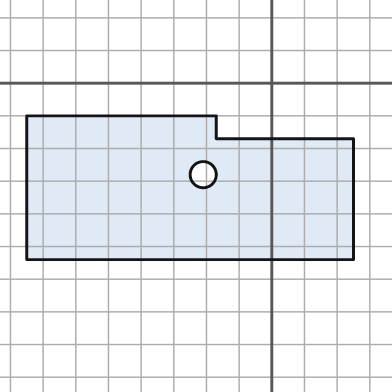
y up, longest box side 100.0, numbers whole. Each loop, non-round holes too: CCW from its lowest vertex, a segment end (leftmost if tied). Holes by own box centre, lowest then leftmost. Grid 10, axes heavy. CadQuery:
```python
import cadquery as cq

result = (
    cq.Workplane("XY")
    .moveTo(-75.0, -54.0)
    .lineTo(25.0, -54.0)
    .lineTo(25.0, -17.0)
    .lineTo(-17.0, -17.0)
    .lineTo(-17.0, -10.0)
    .lineTo(-75.0, -10.0)
    .close()
    .moveTo(-21.0, -28.0)
    .circle(4.0)
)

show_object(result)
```